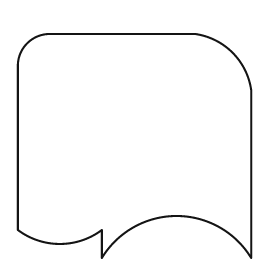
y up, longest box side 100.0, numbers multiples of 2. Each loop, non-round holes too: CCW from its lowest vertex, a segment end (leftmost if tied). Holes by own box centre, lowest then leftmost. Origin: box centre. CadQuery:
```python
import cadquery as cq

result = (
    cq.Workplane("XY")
    .moveTo(-14.0, -48.0)
    .threePointArc((18.0, -30.0), (50.0, -48.0))
    .lineTo(50.0, 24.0)
    .threePointArc((42.0, 40.0), (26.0, 48.0))
    .lineTo(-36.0, 48.0)
    .threePointArc((-46.0, 44.0), (-50.0, 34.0))
    .lineTo(-50.0, -36.0)
    .threePointArc((-32.0, -42.0), (-14.0, -36.0))
    .close()
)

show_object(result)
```